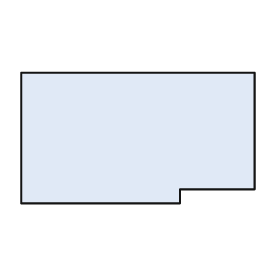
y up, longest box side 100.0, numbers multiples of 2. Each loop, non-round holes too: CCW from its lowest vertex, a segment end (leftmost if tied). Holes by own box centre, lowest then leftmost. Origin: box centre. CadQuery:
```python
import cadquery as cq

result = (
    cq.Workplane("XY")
    .moveTo(-50.0, -28.0)
    .lineTo(18.0, -28.0)
    .lineTo(18.0, -22.0)
    .lineTo(50.0, -22.0)
    .lineTo(50.0, 28.0)
    .lineTo(-50.0, 28.0)
    .close()
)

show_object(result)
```